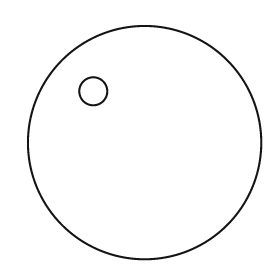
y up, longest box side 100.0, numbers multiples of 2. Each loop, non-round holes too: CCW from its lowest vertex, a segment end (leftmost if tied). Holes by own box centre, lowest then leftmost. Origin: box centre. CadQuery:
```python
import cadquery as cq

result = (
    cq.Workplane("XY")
    .moveTo(0.0, 0.0)
    .circle(50.0)
    .moveTo(-22.0, 22.0)
    .circle(6.0)
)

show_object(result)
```